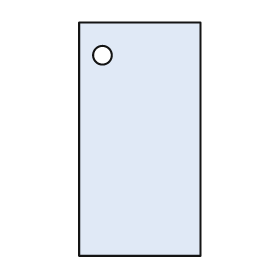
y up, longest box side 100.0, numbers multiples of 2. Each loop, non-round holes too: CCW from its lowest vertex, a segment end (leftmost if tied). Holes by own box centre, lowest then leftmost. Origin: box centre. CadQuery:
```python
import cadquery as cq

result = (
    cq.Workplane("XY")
    .moveTo(-26.0, -50.0)
    .lineTo(26.0, -50.0)
    .lineTo(26.0, 50.0)
    .lineTo(-26.0, 50.0)
    .close()
    .moveTo(-16.0, 36.0)
    .circle(4.0)
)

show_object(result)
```